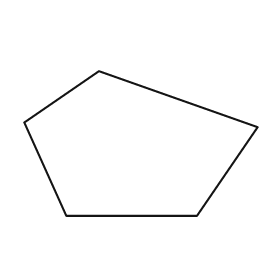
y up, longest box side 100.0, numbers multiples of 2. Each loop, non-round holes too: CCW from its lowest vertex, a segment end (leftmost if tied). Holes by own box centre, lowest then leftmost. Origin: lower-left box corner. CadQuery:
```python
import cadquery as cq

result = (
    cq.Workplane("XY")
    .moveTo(18.0, 0.0)
    .lineTo(74.0, 0.0)
    .lineTo(100.0, 38.0)
    .lineTo(32.0, 62.0)
    .lineTo(0.0, 40.0)
    .close()
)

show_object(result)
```